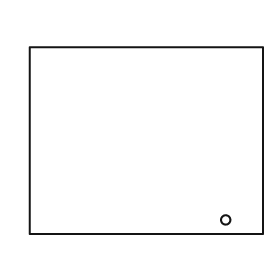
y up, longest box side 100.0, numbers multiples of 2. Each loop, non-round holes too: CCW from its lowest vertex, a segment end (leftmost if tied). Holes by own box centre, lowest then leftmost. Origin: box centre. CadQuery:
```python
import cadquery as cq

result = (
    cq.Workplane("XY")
    .moveTo(-50.0, -40.0)
    .lineTo(50.0, -40.0)
    .lineTo(50.0, 40.0)
    .lineTo(-50.0, 40.0)
    .close()
    .moveTo(34.0, -34.0)
    .circle(2.0)
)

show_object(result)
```